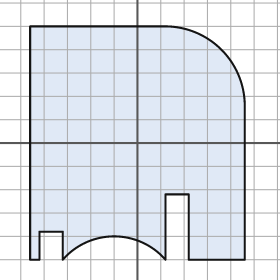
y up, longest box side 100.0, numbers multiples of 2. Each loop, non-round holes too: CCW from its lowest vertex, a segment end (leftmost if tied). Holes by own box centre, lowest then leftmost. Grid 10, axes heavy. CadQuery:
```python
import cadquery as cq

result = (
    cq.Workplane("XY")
    .moveTo(-46.0, -50.0)
    .lineTo(-42.0, -50.0)
    .lineTo(-42.0, -38.0)
    .lineTo(-32.0, -38.0)
    .lineTo(-32.0, -50.0)
    .threePointArc((-10.0, -40.0), (12.0, -50.0))
    .lineTo(12.0, -22.0)
    .lineTo(22.0, -22.0)
    .lineTo(22.0, -50.0)
    .lineTo(46.0, -50.0)
    .lineTo(46.0, 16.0)
    .threePointArc((36.0, 40.0), (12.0, 50.0))
    .lineTo(-46.0, 50.0)
    .close()
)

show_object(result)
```